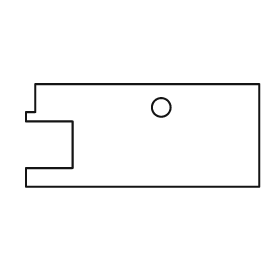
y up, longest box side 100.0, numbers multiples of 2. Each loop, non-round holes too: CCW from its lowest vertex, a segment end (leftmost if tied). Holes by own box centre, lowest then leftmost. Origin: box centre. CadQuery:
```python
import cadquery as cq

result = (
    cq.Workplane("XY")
    .moveTo(-50.0, -22.0)
    .lineTo(50.0, -22.0)
    .lineTo(50.0, 22.0)
    .lineTo(-46.0, 22.0)
    .lineTo(-46.0, 10.0)
    .lineTo(-50.0, 10.0)
    .lineTo(-50.0, 6.0)
    .lineTo(-30.0, 6.0)
    .lineTo(-30.0, -14.0)
    .lineTo(-50.0, -14.0)
    .close()
    .moveTo(8.0, 12.0)
    .circle(4.0)
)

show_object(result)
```